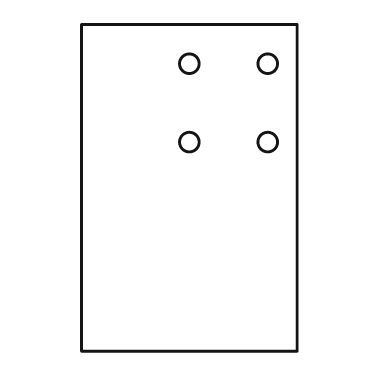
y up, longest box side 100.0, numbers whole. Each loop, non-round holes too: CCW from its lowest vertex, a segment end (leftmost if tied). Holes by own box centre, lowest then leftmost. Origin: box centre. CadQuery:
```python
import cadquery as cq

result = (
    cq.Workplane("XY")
    .moveTo(-33.0, -50.0)
    .lineTo(33.0, -50.0)
    .lineTo(33.0, 50.0)
    .lineTo(-33.0, 50.0)
    .close()
    .moveTo(0.0, 14.0)
    .circle(3.0)
    .moveTo(24.0, 14.0)
    .circle(3.0)
    .moveTo(0.0, 38.0)
    .circle(3.0)
    .moveTo(24.0, 38.0)
    .circle(3.0)
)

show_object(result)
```